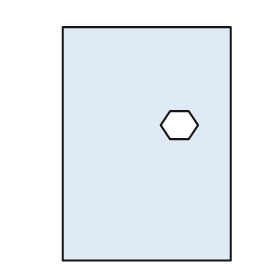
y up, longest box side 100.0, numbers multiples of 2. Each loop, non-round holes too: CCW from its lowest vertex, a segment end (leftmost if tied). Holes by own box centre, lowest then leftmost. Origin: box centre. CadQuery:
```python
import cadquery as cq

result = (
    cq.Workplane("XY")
    .moveTo(-36.0, -50.0)
    .lineTo(36.0, -50.0)
    .lineTo(36.0, 50.0)
    .lineTo(-36.0, 50.0)
    .close()
    .moveTo(10.0, 2.0)
    .lineTo(18.0, 2.0)
    .lineTo(22.0, 8.0)
    .lineTo(18.0, 14.0)
    .lineTo(10.0, 14.0)
    .lineTo(6.0, 8.0)
    .close()
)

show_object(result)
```